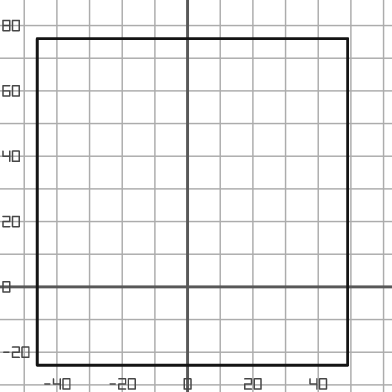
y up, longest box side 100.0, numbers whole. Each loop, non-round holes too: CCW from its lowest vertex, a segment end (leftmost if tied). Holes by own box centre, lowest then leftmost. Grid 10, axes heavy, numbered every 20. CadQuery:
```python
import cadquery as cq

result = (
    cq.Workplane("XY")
    .moveTo(-46.0, -24.0)
    .lineTo(49.0, -24.0)
    .lineTo(49.0, 76.0)
    .lineTo(-46.0, 76.0)
    .close()
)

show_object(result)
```